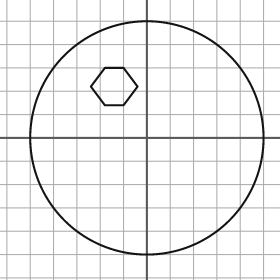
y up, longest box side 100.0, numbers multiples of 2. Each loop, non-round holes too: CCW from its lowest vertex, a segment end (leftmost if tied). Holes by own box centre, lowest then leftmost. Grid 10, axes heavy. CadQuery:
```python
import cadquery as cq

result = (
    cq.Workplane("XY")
    .moveTo(0.0, 0.0)
    .circle(50.0)
    .moveTo(-18.0, 14.0)
    .lineTo(-10.0, 14.0)
    .lineTo(-4.0, 22.0)
    .lineTo(-10.0, 30.0)
    .lineTo(-18.0, 30.0)
    .lineTo(-24.0, 22.0)
    .close()
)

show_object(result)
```